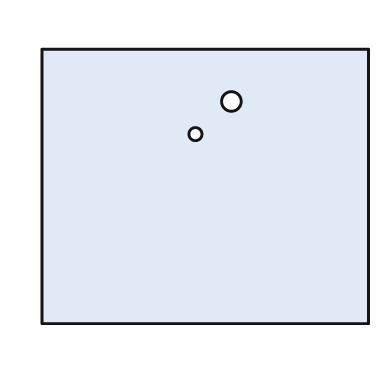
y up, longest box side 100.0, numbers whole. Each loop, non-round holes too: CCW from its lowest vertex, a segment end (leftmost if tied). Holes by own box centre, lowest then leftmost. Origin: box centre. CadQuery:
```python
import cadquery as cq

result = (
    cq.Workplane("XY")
    .moveTo(-50.0, -42.0)
    .lineTo(50.0, -42.0)
    .lineTo(50.0, 42.0)
    .lineTo(-50.0, 42.0)
    .close()
    .moveTo(-3.0, 16.0)
    .circle(2.0)
    .moveTo(8.0, 26.0)
    .circle(3.0)
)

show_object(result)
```